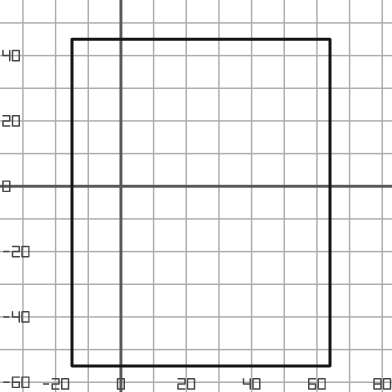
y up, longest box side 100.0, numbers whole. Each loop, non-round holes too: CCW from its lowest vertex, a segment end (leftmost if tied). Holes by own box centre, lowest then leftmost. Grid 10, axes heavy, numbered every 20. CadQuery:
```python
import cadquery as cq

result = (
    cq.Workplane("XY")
    .moveTo(-15.0, -55.0)
    .lineTo(64.0, -55.0)
    .lineTo(64.0, 45.0)
    .lineTo(-15.0, 45.0)
    .close()
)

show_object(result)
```